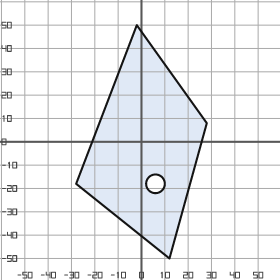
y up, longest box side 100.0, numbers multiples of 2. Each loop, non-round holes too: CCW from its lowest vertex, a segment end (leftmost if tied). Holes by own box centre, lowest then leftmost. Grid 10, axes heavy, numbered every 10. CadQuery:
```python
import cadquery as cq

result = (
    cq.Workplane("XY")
    .moveTo(12.0, -50.0)
    .lineTo(28.0, 8.0)
    .lineTo(-2.0, 50.0)
    .lineTo(-28.0, -18.0)
    .close()
    .moveTo(6.0, -18.0)
    .circle(4.0)
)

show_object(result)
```